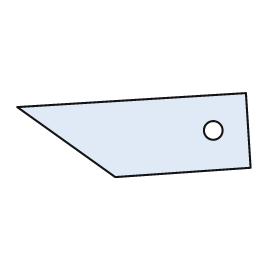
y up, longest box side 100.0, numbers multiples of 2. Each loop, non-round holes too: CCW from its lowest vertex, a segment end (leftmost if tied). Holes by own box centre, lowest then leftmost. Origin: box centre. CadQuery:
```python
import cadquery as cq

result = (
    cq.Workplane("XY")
    .moveTo(-8.0, -18.0)
    .lineTo(50.0, -14.0)
    .lineTo(48.0, 18.0)
    .lineTo(-50.0, 12.0)
    .close()
    .moveTo(34.0, 2.0)
    .circle(4.0)
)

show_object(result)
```